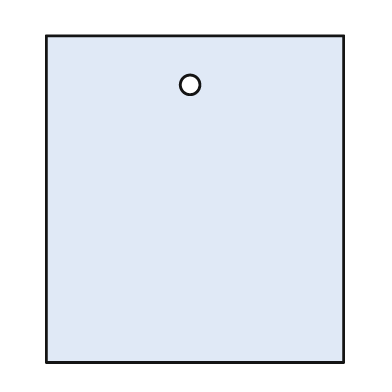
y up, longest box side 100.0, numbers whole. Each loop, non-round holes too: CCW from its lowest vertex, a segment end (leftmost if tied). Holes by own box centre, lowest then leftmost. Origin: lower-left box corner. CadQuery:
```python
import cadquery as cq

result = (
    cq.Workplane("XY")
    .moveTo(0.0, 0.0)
    .lineTo(91.0, 0.0)
    .lineTo(91.0, 100.0)
    .lineTo(0.0, 100.0)
    .close()
    .moveTo(44.0, 85.0)
    .circle(3.0)
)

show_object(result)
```